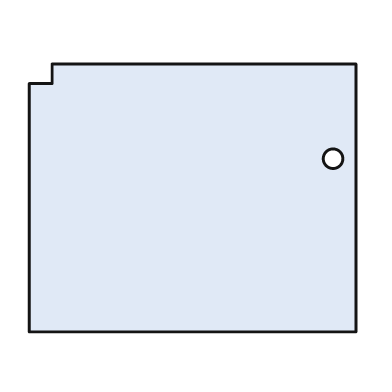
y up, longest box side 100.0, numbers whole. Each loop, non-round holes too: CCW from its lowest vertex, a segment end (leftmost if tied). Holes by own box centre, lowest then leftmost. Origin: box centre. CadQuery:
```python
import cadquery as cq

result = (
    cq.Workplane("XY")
    .moveTo(-50.0, -41.0)
    .lineTo(50.0, -41.0)
    .lineTo(50.0, 41.0)
    .lineTo(-43.0, 41.0)
    .lineTo(-43.0, 35.0)
    .lineTo(-50.0, 35.0)
    .close()
    .moveTo(43.0, 12.0)
    .circle(3.0)
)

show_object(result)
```